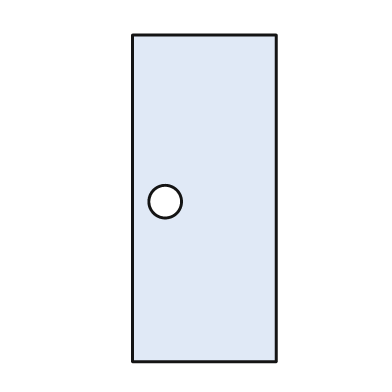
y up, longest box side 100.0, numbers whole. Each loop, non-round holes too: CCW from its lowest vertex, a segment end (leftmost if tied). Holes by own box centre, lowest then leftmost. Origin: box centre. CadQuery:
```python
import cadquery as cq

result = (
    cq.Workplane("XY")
    .moveTo(-22.0, -50.0)
    .lineTo(22.0, -50.0)
    .lineTo(22.0, 50.0)
    .lineTo(-22.0, 50.0)
    .close()
    .moveTo(-12.0, -1.0)
    .circle(5.0)
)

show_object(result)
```